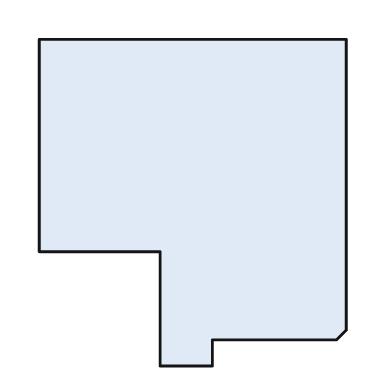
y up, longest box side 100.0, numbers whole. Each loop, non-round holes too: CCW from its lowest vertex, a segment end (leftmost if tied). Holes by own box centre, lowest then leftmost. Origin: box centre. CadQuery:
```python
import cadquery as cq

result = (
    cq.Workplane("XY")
    .moveTo(-10.0, -50.0)
    .lineTo(6.0, -50.0)
    .lineTo(6.0, -42.0)
    .lineTo(44.0, -42.0)
    .lineTo(47.0, -39.0)
    .lineTo(47.0, 50.0)
    .lineTo(-47.0, 50.0)
    .lineTo(-47.0, -15.0)
    .lineTo(-10.0, -15.0)
    .close()
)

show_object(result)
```